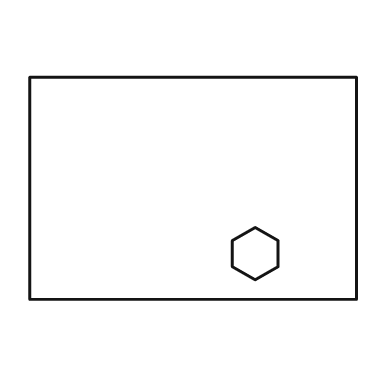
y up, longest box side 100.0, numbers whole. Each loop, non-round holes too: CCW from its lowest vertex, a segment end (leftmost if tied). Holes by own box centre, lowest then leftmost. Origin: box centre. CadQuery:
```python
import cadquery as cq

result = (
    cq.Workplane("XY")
    .moveTo(-50.0, -34.0)
    .lineTo(50.0, -34.0)
    .lineTo(50.0, 34.0)
    .lineTo(-50.0, 34.0)
    .close()
    .moveTo(19.0, -28.0)
    .lineTo(26.0, -24.0)
    .lineTo(26.0, -16.0)
    .lineTo(19.0, -12.0)
    .lineTo(12.0, -16.0)
    .lineTo(12.0, -24.0)
    .close()
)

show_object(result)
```